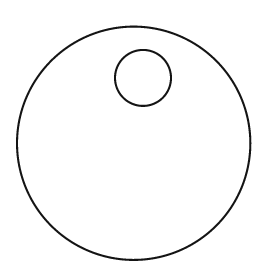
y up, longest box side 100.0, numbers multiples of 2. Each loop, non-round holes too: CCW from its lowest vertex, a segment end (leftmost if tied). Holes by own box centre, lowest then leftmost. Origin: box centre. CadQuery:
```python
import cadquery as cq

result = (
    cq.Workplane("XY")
    .moveTo(0.0, 0.0)
    .circle(50.0)
    .moveTo(4.0, 28.0)
    .circle(12.0)
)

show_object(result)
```